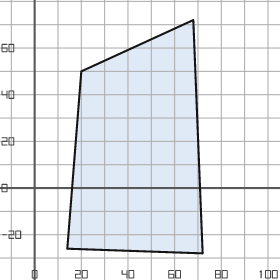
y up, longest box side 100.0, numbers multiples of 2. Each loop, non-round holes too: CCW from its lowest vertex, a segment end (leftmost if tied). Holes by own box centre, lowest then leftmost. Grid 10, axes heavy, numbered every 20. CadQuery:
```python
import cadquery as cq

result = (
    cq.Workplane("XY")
    .moveTo(72.0, -28.0)
    .lineTo(68.0, 72.0)
    .lineTo(20.0, 50.0)
    .lineTo(14.0, -26.0)
    .close()
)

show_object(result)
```